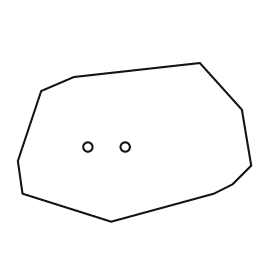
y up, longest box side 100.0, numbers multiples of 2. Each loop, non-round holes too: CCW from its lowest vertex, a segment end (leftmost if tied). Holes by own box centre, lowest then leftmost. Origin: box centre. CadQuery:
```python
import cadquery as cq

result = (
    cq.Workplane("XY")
    .moveTo(-10.0, -34.0)
    .lineTo(34.0, -22.0)
    .lineTo(42.0, -18.0)
    .lineTo(50.0, -10.0)
    .lineTo(46.0, 14.0)
    .lineTo(28.0, 34.0)
    .lineTo(-26.0, 28.0)
    .lineTo(-40.0, 22.0)
    .lineTo(-50.0, -8.0)
    .lineTo(-48.0, -22.0)
    .close()
    .moveTo(-20.0, -2.0)
    .circle(2.0)
    .moveTo(-4.0, -2.0)
    .circle(2.0)
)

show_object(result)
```